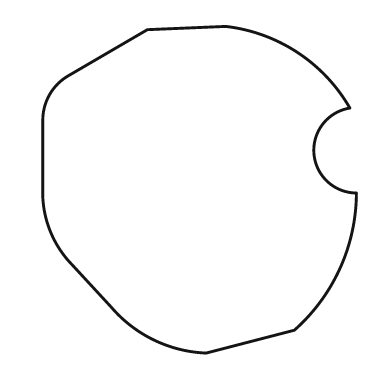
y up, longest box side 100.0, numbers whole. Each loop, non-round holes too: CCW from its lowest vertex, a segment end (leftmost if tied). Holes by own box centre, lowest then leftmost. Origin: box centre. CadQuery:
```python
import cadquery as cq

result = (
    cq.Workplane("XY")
    .moveTo(2.0, -50.0)
    .lineTo(29.0, -43.0)
    .threePointArc((43.0, -24.0), (48.0, -1.0))
    .threePointArc((35.0, 11.0), (46.0, 25.0))
    .threePointArc((30.0, 42.0), (8.0, 50.0))
    .lineTo(-16.0, 49.0)
    .lineTo(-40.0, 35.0)
    .threePointArc((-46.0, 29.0), (-48.0, 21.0))
    .lineTo(-48.0, 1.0)
    .threePointArc((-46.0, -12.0), (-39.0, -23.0))
    .lineTo(-27.0, -36.0)
    .threePointArc((-14.0, -46.0), (2.0, -50.0))
    .close()
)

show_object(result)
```